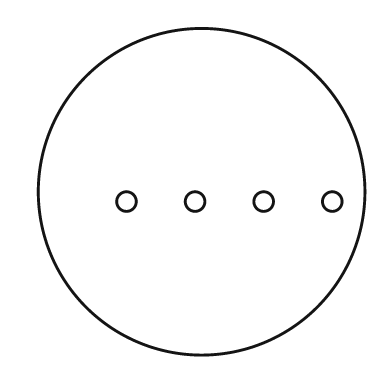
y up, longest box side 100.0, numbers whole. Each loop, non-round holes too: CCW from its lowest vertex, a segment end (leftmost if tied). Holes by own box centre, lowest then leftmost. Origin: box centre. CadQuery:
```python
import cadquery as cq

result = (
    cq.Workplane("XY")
    .moveTo(0.0, 0.0)
    .circle(50.0)
    .moveTo(-23.0, -3.0)
    .circle(3.0)
    .moveTo(-2.0, -3.0)
    .circle(3.0)
    .moveTo(19.0, -3.0)
    .circle(3.0)
    .moveTo(40.0, -3.0)
    .circle(3.0)
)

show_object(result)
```